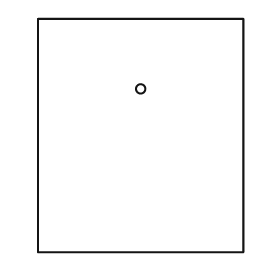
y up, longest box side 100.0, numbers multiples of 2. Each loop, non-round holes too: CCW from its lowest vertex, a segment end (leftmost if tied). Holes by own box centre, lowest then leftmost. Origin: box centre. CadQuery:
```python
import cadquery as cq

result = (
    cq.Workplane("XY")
    .moveTo(-44.0, -50.0)
    .lineTo(44.0, -50.0)
    .lineTo(44.0, 50.0)
    .lineTo(-44.0, 50.0)
    .close()
    .moveTo(0.0, 20.0)
    .circle(2.0)
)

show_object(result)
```